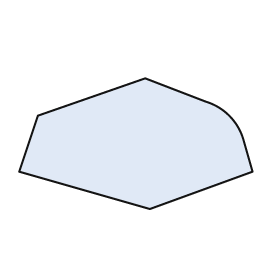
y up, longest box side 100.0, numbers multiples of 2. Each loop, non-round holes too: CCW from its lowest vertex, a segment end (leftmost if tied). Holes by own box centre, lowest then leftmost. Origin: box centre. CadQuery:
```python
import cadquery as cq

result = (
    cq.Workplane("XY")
    .moveTo(6.0, -28.0)
    .lineTo(50.0, -12.0)
    .lineTo(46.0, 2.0)
    .threePointArc((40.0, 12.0), (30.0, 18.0))
    .lineTo(4.0, 28.0)
    .lineTo(-42.0, 12.0)
    .lineTo(-50.0, -12.0)
    .close()
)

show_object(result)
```